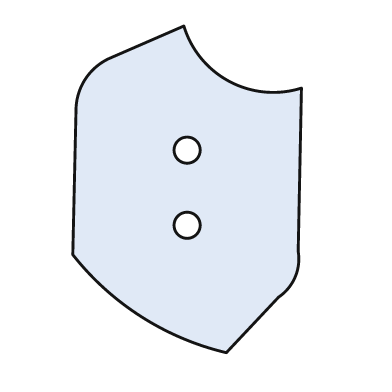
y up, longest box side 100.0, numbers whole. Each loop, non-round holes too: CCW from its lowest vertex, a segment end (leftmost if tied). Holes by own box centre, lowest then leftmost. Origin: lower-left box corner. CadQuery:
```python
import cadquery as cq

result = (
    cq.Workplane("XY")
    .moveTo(47.0, 0.0)
    .lineTo(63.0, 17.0)
    .threePointArc((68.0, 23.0), (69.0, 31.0))
    .lineTo(70.0, 81.0)
    .threePointArc((48.0, 83.0), (34.0, 100.0))
    .lineTo(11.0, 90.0)
    .threePointArc((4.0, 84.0), (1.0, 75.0))
    .lineTo(0.0, 30.0)
    .threePointArc((21.0, 11.0), (47.0, 0.0))
    .close()
    .moveTo(35.0, 39.0)
    .circle(4.0)
    .moveTo(35.0, 62.0)
    .circle(4.0)
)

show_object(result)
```